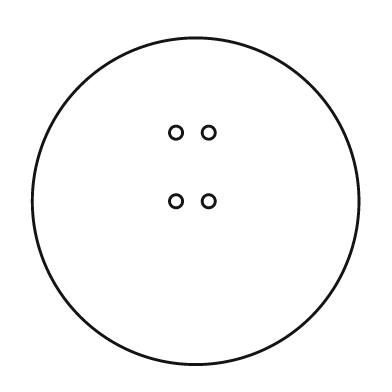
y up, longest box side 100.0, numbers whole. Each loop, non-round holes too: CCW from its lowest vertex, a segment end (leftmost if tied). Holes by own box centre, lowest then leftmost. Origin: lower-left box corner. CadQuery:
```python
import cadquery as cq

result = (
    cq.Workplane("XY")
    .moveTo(50.0, 50.0)
    .circle(50.0)
    .moveTo(44.0, 50.0)
    .circle(2.0)
    .moveTo(54.0, 50.0)
    .circle(2.0)
    .moveTo(44.0, 71.0)
    .circle(2.0)
    .moveTo(54.0, 71.0)
    .circle(2.0)
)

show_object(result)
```